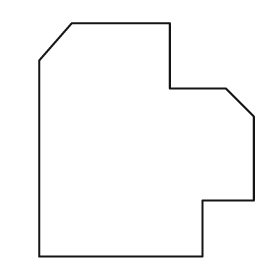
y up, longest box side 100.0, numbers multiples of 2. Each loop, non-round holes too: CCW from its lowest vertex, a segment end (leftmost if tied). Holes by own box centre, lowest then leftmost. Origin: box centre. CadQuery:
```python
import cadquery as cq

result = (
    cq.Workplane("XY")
    .moveTo(-46.0, -50.0)
    .lineTo(24.0, -50.0)
    .lineTo(24.0, -26.0)
    .lineTo(46.0, -26.0)
    .lineTo(46.0, 10.0)
    .lineTo(34.0, 22.0)
    .lineTo(10.0, 22.0)
    .lineTo(10.0, 50.0)
    .lineTo(-32.0, 50.0)
    .lineTo(-46.0, 34.0)
    .close()
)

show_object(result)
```